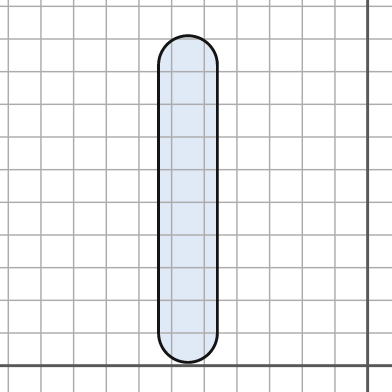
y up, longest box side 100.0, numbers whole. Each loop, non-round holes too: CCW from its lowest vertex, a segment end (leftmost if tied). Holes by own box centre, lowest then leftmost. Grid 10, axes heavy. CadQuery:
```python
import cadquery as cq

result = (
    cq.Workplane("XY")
    .moveTo(-64.0, 10.0)
    .threePointArc((-55.0, 1.0), (-46.0, 10.0))
    .lineTo(-46.0, 92.0)
    .threePointArc((-55.0, 101.0), (-64.0, 92.0))
    .close()
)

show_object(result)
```